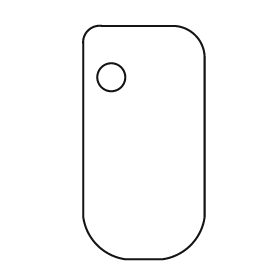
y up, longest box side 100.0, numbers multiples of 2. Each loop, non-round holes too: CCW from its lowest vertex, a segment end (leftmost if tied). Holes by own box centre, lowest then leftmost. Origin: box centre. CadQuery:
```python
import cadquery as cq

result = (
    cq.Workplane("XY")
    .moveTo(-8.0, -50.0)
    .lineTo(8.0, -50.0)
    .threePointArc((20.0, -44.0), (26.0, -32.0))
    .lineTo(26.0, 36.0)
    .threePointArc((22.0, 46.0), (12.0, 50.0))
    .lineTo(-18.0, 50.0)
    .threePointArc((-24.0, 48.0), (-26.0, 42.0))
    .lineTo(-26.0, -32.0)
    .threePointArc((-20.0, -44.0), (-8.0, -50.0))
    .close()
    .moveTo(-14.0, 28.0)
    .circle(6.0)
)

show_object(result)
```